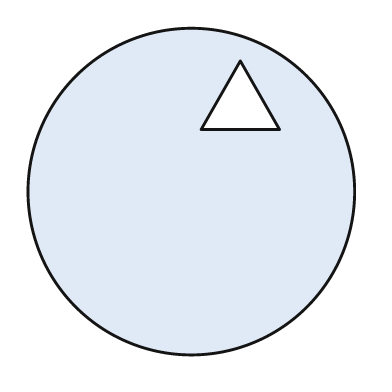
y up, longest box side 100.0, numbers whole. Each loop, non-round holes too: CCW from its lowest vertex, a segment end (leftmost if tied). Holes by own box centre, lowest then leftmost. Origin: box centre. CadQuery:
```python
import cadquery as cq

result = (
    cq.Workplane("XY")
    .moveTo(0.0, 0.0)
    .circle(50.0)
    .moveTo(3.0, 19.0)
    .lineTo(27.0, 19.0)
    .lineTo(15.0, 40.0)
    .close()
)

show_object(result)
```